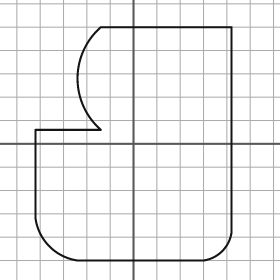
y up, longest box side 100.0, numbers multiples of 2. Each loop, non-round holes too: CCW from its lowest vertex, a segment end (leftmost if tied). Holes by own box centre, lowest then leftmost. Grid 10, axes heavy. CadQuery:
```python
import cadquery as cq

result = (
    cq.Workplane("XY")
    .moveTo(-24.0, -50.0)
    .lineTo(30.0, -50.0)
    .threePointArc((38.0, -46.0), (42.0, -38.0))
    .lineTo(42.0, 50.0)
    .lineTo(-14.0, 50.0)
    .threePointArc((-24.0, 28.0), (-14.0, 6.0))
    .lineTo(-42.0, 6.0)
    .lineTo(-42.0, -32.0)
    .threePointArc((-36.0, -44.0), (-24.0, -50.0))
    .close()
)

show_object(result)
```